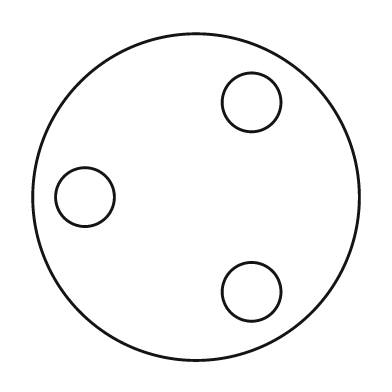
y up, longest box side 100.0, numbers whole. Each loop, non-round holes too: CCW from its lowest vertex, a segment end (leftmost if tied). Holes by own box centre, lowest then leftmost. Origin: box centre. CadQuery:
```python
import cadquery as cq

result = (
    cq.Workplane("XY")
    .moveTo(0.0, 0.0)
    .circle(50.0)
    .moveTo(17.0, -29.0)
    .circle(9.0)
    .moveTo(-34.0, 0.0)
    .circle(9.0)
    .moveTo(17.0, 29.0)
    .circle(9.0)
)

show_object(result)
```